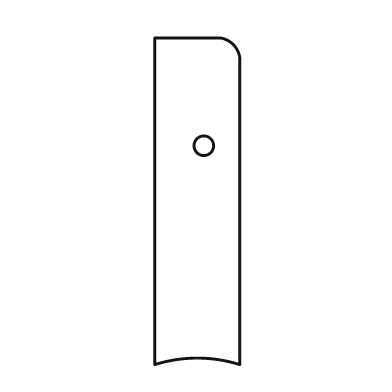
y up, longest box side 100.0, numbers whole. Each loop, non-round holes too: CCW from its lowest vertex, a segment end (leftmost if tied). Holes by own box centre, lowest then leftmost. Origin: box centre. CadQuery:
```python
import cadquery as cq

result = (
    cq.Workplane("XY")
    .moveTo(-13.0, -50.0)
    .threePointArc((0.0, -48.0), (13.0, -50.0))
    .lineTo(13.0, 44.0)
    .threePointArc((11.0, 48.0), (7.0, 50.0))
    .lineTo(-13.0, 50.0)
    .close()
    .moveTo(2.0, 17.0)
    .circle(3.0)
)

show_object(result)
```